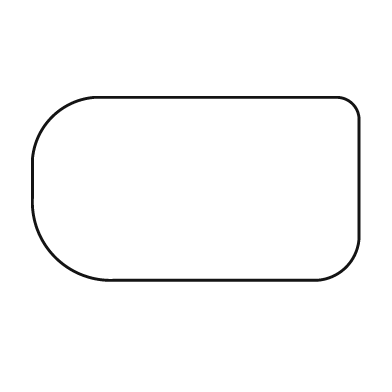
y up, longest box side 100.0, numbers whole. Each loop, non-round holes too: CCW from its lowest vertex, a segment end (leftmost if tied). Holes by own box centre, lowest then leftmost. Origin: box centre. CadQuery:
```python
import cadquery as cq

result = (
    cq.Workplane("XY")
    .moveTo(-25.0, -28.0)
    .lineTo(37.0, -28.0)
    .threePointArc((46.0, -24.0), (50.0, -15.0))
    .lineTo(50.0, 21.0)
    .threePointArc((48.0, 26.0), (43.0, 28.0))
    .lineTo(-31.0, 28.0)
    .threePointArc((-44.0, 22.0), (-50.0, 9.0))
    .lineTo(-50.0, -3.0)
    .threePointArc((-43.0, -21.0), (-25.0, -28.0))
    .close()
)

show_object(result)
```